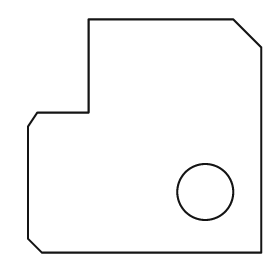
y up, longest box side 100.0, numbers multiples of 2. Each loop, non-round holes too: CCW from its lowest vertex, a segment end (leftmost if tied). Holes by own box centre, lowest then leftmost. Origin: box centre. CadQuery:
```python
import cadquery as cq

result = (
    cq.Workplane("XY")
    .moveTo(-44.0, -50.0)
    .lineTo(50.0, -50.0)
    .lineTo(50.0, 38.0)
    .lineTo(38.0, 50.0)
    .lineTo(-24.0, 50.0)
    .lineTo(-24.0, 10.0)
    .lineTo(-46.0, 10.0)
    .lineTo(-50.0, 4.0)
    .lineTo(-50.0, -44.0)
    .close()
    .moveTo(26.0, -24.0)
    .circle(12.0)
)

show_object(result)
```